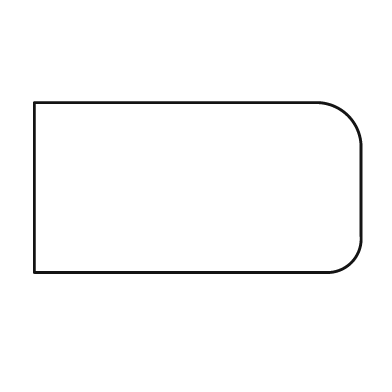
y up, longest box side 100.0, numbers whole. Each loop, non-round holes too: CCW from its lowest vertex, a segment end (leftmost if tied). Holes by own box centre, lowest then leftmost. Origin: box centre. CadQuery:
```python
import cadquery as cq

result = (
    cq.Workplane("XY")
    .moveTo(-50.0, -26.0)
    .lineTo(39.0, -26.0)
    .threePointArc((47.0, -23.0), (50.0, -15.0))
    .lineTo(50.0, 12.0)
    .threePointArc((46.0, 22.0), (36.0, 26.0))
    .lineTo(-50.0, 26.0)
    .close()
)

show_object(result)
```